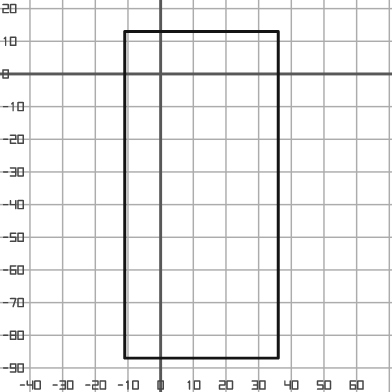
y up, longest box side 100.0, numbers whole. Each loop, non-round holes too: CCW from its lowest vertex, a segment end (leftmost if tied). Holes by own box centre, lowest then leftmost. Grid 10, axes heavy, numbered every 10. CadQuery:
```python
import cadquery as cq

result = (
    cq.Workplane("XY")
    .moveTo(-11.0, -87.0)
    .lineTo(36.0, -87.0)
    .lineTo(36.0, 13.0)
    .lineTo(-11.0, 13.0)
    .close()
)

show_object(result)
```